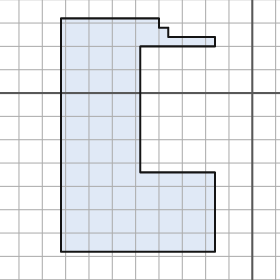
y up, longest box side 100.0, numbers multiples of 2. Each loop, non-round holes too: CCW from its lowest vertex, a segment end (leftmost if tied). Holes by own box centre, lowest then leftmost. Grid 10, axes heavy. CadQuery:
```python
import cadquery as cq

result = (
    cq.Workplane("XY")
    .moveTo(-82.0, -68.0)
    .lineTo(-16.0, -68.0)
    .lineTo(-16.0, -34.0)
    .lineTo(-48.0, -34.0)
    .lineTo(-48.0, 20.0)
    .lineTo(-16.0, 20.0)
    .lineTo(-16.0, 24.0)
    .lineTo(-36.0, 24.0)
    .lineTo(-36.0, 28.0)
    .lineTo(-40.0, 28.0)
    .lineTo(-40.0, 32.0)
    .lineTo(-82.0, 32.0)
    .close()
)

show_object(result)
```